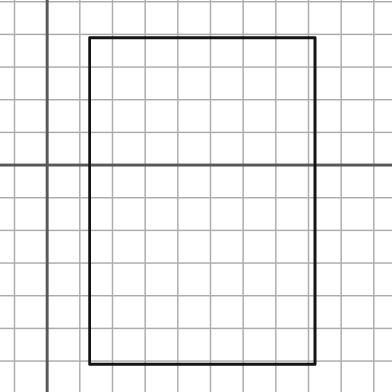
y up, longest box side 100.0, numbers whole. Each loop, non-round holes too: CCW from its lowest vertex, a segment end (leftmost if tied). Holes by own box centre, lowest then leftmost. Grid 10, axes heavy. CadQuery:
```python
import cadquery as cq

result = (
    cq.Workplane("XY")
    .moveTo(13.0, -61.0)
    .lineTo(82.0, -61.0)
    .lineTo(82.0, 39.0)
    .lineTo(13.0, 39.0)
    .close()
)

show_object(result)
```